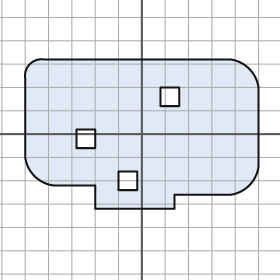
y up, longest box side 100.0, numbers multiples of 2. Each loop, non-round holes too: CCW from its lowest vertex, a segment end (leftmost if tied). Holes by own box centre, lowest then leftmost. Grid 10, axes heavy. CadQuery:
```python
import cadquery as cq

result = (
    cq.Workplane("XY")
    .moveTo(-20.0, -32.0)
    .lineTo(14.0, -32.0)
    .lineTo(14.0, -26.0)
    .lineTo(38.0, -26.0)
    .threePointArc((46.0, -22.0), (50.0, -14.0))
    .lineTo(50.0, 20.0)
    .threePointArc((46.0, 28.0), (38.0, 32.0))
    .lineTo(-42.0, 32.0)
    .threePointArc((-48.0, 30.0), (-50.0, 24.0))
    .lineTo(-50.0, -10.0)
    .threePointArc((-46.0, -18.0), (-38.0, -22.0))
    .lineTo(-20.0, -22.0)
    .close()
    .moveTo(-10.0, -24.0)
    .lineTo(-2.0, -24.0)
    .lineTo(-2.0, -16.0)
    .lineTo(-10.0, -16.0)
    .close()
    .moveTo(-28.0, -6.0)
    .lineTo(-20.0, -6.0)
    .lineTo(-20.0, 2.0)
    .lineTo(-28.0, 2.0)
    .close()
    .moveTo(8.0, 12.0)
    .lineTo(16.0, 12.0)
    .lineTo(16.0, 20.0)
    .lineTo(8.0, 20.0)
    .close()
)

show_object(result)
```